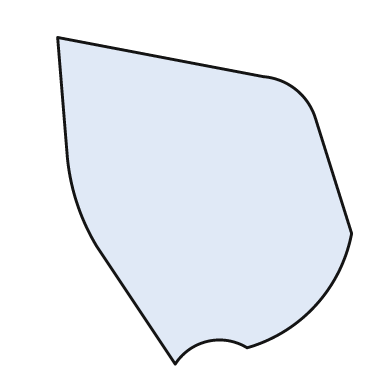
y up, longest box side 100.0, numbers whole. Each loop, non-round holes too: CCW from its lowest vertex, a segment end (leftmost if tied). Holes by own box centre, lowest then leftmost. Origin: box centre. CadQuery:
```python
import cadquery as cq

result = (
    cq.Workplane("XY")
    .moveTo(-9.0, -50.0)
    .threePointArc((1.0, -43.0), (13.0, -45.0))
    .threePointArc((34.0, -32.0), (45.0, -10.0))
    .lineTo(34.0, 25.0)
    .threePointArc((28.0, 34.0), (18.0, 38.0))
    .lineTo(-45.0, 50.0)
    .lineTo(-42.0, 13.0)
    .threePointArc((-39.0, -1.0), (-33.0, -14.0))
    .close()
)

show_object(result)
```